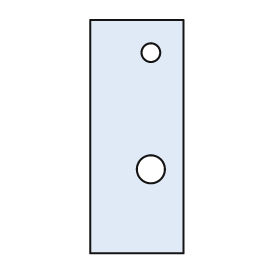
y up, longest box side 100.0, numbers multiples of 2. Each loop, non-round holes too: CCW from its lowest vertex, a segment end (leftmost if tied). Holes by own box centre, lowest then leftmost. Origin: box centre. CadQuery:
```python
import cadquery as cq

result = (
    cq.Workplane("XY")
    .moveTo(-20.0, -50.0)
    .lineTo(20.0, -50.0)
    .lineTo(20.0, 50.0)
    .lineTo(-20.0, 50.0)
    .close()
    .moveTo(6.0, -14.0)
    .circle(6.0)
    .moveTo(6.0, 36.0)
    .circle(4.0)
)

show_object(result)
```